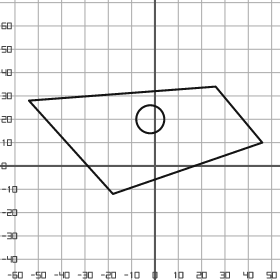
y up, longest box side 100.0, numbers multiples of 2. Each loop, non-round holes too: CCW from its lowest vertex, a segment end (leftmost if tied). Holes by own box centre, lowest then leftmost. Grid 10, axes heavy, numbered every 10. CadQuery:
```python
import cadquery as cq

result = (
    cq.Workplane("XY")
    .moveTo(-18.0, -12.0)
    .lineTo(46.0, 10.0)
    .lineTo(26.0, 34.0)
    .lineTo(-54.0, 28.0)
    .close()
    .moveTo(-2.0, 20.0)
    .circle(6.0)
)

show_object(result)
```